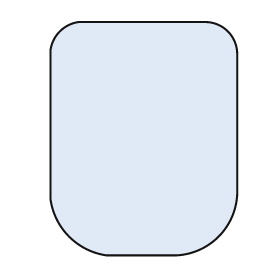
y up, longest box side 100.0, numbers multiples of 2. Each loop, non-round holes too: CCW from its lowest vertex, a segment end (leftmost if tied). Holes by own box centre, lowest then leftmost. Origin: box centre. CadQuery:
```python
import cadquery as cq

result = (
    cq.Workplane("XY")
    .moveTo(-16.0, -50.0)
    .lineTo(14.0, -50.0)
    .threePointArc((32.0, -42.0), (40.0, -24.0))
    .lineTo(40.0, 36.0)
    .threePointArc((36.0, 46.0), (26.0, 50.0))
    .lineTo(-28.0, 50.0)
    .threePointArc((-36.0, 46.0), (-40.0, 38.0))
    .lineTo(-40.0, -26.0)
    .threePointArc((-32.0, -42.0), (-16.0, -50.0))
    .close()
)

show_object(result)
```